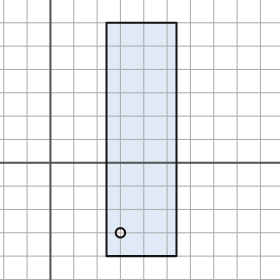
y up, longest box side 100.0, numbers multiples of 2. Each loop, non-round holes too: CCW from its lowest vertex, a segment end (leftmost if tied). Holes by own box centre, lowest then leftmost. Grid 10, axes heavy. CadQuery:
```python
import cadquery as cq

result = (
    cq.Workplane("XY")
    .moveTo(24.0, -40.0)
    .lineTo(54.0, -40.0)
    .lineTo(54.0, 60.0)
    .lineTo(24.0, 60.0)
    .close()
    .moveTo(30.0, -30.0)
    .circle(2.0)
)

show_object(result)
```